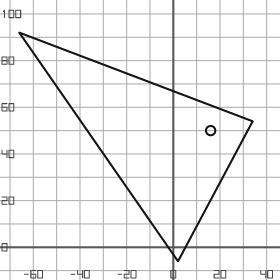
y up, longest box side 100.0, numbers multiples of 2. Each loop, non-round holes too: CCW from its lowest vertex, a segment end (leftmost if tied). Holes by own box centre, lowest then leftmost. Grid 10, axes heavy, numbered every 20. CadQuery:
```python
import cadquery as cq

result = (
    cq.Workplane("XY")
    .moveTo(2.0, -6.0)
    .lineTo(34.0, 54.0)
    .lineTo(-66.0, 92.0)
    .close()
    .moveTo(16.0, 50.0)
    .circle(2.0)
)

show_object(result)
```